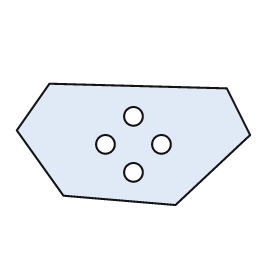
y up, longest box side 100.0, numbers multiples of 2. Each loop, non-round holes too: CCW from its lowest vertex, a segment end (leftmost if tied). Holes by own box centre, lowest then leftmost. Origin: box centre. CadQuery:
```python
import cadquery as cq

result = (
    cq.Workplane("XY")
    .moveTo(18.0, -26.0)
    .lineTo(50.0, 4.0)
    .lineTo(40.0, 24.0)
    .lineTo(-36.0, 26.0)
    .lineTo(-50.0, 6.0)
    .lineTo(-30.0, -22.0)
    .close()
    .moveTo(0.0, -12.0)
    .circle(4.0)
    .moveTo(-12.0, 0.0)
    .circle(4.0)
    .moveTo(12.0, 0.0)
    .circle(4.0)
    .moveTo(0.0, 12.0)
    .circle(4.0)
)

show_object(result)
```